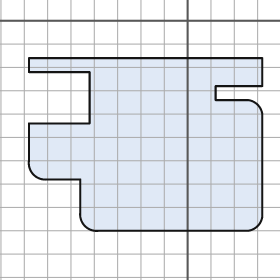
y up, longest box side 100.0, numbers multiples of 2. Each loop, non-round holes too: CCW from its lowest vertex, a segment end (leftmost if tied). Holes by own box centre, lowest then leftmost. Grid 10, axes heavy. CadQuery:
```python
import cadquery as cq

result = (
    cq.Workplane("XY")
    .moveTo(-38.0, -90.0)
    .lineTo(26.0, -90.0)
    .threePointArc((30.0, -88.0), (32.0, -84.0))
    .lineTo(32.0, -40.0)
    .threePointArc((30.0, -36.0), (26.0, -34.0))
    .lineTo(12.0, -34.0)
    .lineTo(12.0, -28.0)
    .lineTo(32.0, -28.0)
    .lineTo(32.0, -16.0)
    .lineTo(-68.0, -16.0)
    .lineTo(-68.0, -22.0)
    .lineTo(-42.0, -22.0)
    .lineTo(-42.0, -44.0)
    .lineTo(-68.0, -44.0)
    .lineTo(-68.0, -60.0)
    .threePointArc((-66.0, -66.0), (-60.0, -68.0))
    .lineTo(-46.0, -68.0)
    .lineTo(-46.0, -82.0)
    .threePointArc((-44.0, -88.0), (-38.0, -90.0))
    .close()
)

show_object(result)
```